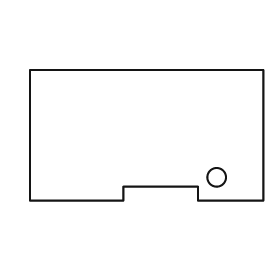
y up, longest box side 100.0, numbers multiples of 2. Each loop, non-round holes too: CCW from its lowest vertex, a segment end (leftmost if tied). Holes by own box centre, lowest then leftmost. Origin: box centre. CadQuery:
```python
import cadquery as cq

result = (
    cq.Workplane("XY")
    .moveTo(-50.0, -28.0)
    .lineTo(-10.0, -28.0)
    .lineTo(-10.0, -22.0)
    .lineTo(22.0, -22.0)
    .lineTo(22.0, -28.0)
    .lineTo(50.0, -28.0)
    .lineTo(50.0, 28.0)
    .lineTo(-50.0, 28.0)
    .close()
    .moveTo(30.0, -18.0)
    .circle(4.0)
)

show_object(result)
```